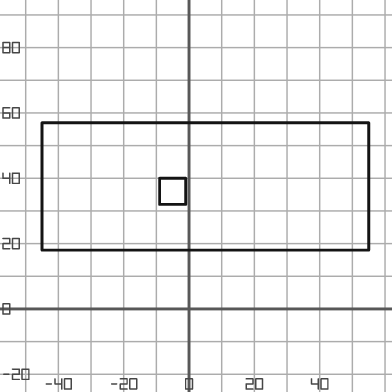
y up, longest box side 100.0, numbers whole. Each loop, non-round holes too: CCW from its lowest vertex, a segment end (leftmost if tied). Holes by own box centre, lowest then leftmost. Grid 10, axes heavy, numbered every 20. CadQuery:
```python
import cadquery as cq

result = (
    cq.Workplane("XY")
    .moveTo(-45.0, 18.0)
    .lineTo(55.0, 18.0)
    .lineTo(55.0, 57.0)
    .lineTo(-45.0, 57.0)
    .close()
    .moveTo(-9.0, 32.0)
    .lineTo(-1.0, 32.0)
    .lineTo(-1.0, 40.0)
    .lineTo(-9.0, 40.0)
    .close()
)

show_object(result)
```